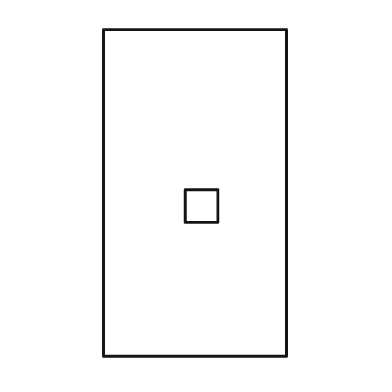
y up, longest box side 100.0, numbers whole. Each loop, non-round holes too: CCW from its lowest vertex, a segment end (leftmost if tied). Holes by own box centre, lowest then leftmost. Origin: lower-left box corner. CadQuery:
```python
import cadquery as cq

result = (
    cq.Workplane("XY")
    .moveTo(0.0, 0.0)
    .lineTo(56.0, 0.0)
    .lineTo(56.0, 100.0)
    .lineTo(0.0, 100.0)
    .close()
    .moveTo(25.0, 41.0)
    .lineTo(35.0, 41.0)
    .lineTo(35.0, 51.0)
    .lineTo(25.0, 51.0)
    .close()
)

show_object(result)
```